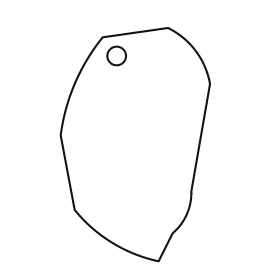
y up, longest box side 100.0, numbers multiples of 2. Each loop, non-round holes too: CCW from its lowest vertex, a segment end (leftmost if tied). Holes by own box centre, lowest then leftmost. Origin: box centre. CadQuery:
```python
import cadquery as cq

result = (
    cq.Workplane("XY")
    .moveTo(10.0, -50.0)
    .lineTo(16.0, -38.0)
    .threePointArc((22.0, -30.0), (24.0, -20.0))
    .lineTo(32.0, 26.0)
    .threePointArc((26.0, 40.0), (14.0, 50.0))
    .lineTo(-14.0, 46.0)
    .threePointArc((-26.0, 26.0), (-32.0, 4.0))
    .lineTo(-26.0, -28.0)
    .threePointArc((-10.0, -42.0), (10.0, -50.0))
    .close()
    .moveTo(-8.0, 38.0)
    .circle(4.0)
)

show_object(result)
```